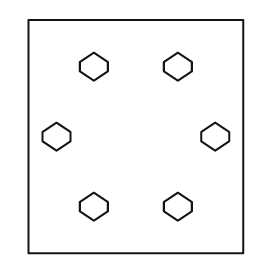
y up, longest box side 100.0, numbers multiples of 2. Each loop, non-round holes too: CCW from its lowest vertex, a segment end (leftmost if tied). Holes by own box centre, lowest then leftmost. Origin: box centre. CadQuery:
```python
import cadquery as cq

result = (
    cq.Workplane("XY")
    .moveTo(-46.0, -50.0)
    .lineTo(46.0, -50.0)
    .lineTo(46.0, 50.0)
    .lineTo(-46.0, 50.0)
    .close()
    .moveTo(-18.0, -36.0)
    .lineTo(-12.0, -32.0)
    .lineTo(-12.0, -28.0)
    .lineTo(-18.0, -24.0)
    .lineTo(-24.0, -28.0)
    .lineTo(-24.0, -32.0)
    .close()
    .moveTo(18.0, -36.0)
    .lineTo(24.0, -32.0)
    .lineTo(24.0, -28.0)
    .lineTo(18.0, -24.0)
    .lineTo(12.0, -28.0)
    .lineTo(12.0, -32.0)
    .close()
    .moveTo(-34.0, -6.0)
    .lineTo(-28.0, -2.0)
    .lineTo(-28.0, 2.0)
    .lineTo(-34.0, 6.0)
    .lineTo(-40.0, 2.0)
    .lineTo(-40.0, -2.0)
    .close()
    .moveTo(34.0, -6.0)
    .lineTo(40.0, -2.0)
    .lineTo(40.0, 2.0)
    .lineTo(34.0, 6.0)
    .lineTo(28.0, 2.0)
    .lineTo(28.0, -2.0)
    .close()
    .moveTo(-18.0, 24.0)
    .lineTo(-12.0, 28.0)
    .lineTo(-12.0, 32.0)
    .lineTo(-18.0, 36.0)
    .lineTo(-24.0, 32.0)
    .lineTo(-24.0, 28.0)
    .close()
    .moveTo(18.0, 24.0)
    .lineTo(24.0, 28.0)
    .lineTo(24.0, 32.0)
    .lineTo(18.0, 36.0)
    .lineTo(12.0, 32.0)
    .lineTo(12.0, 28.0)
    .close()
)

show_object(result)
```